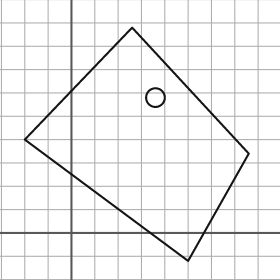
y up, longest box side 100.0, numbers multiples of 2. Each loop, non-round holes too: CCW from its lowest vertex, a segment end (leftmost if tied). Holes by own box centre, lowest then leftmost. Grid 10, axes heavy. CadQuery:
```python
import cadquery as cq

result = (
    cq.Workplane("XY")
    .moveTo(50.0, -12.0)
    .lineTo(76.0, 34.0)
    .lineTo(26.0, 88.0)
    .lineTo(-20.0, 40.0)
    .close()
    .moveTo(36.0, 58.0)
    .circle(4.0)
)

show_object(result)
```